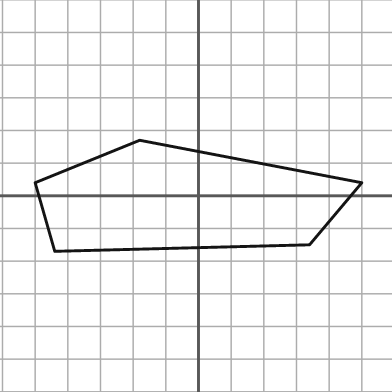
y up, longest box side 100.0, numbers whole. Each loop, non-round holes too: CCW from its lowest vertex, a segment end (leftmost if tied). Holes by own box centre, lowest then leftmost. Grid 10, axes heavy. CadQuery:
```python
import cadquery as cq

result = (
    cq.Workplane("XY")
    .moveTo(-44.0, -17.0)
    .lineTo(34.0, -15.0)
    .lineTo(50.0, 4.0)
    .lineTo(-18.0, 17.0)
    .lineTo(-50.0, 4.0)
    .close()
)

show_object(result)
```